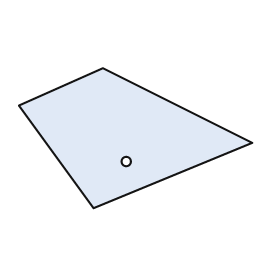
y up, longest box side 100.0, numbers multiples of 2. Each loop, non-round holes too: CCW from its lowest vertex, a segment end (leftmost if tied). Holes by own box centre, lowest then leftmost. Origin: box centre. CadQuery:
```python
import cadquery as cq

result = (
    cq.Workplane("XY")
    .moveTo(-18.0, -30.0)
    .lineTo(50.0, -2.0)
    .lineTo(-14.0, 30.0)
    .lineTo(-50.0, 14.0)
    .close()
    .moveTo(-4.0, -10.0)
    .circle(2.0)
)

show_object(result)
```